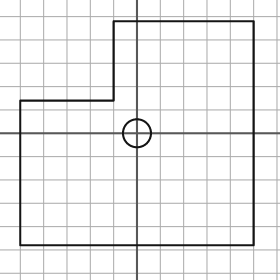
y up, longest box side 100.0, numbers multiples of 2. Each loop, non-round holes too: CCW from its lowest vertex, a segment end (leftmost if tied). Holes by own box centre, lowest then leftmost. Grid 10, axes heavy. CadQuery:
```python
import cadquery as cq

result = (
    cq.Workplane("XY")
    .moveTo(-50.0, -48.0)
    .lineTo(50.0, -48.0)
    .lineTo(50.0, 48.0)
    .lineTo(-10.0, 48.0)
    .lineTo(-10.0, 14.0)
    .lineTo(-50.0, 14.0)
    .close()
    .moveTo(0.0, 0.0)
    .circle(6.0)
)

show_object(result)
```